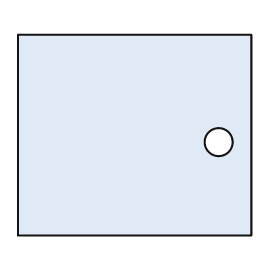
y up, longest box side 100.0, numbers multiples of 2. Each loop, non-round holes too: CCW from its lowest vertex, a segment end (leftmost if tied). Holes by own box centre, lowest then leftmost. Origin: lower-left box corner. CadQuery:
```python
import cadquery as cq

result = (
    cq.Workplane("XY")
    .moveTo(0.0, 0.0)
    .lineTo(100.0, 0.0)
    .lineTo(100.0, 86.0)
    .lineTo(0.0, 86.0)
    .close()
    .moveTo(86.0, 40.0)
    .circle(6.0)
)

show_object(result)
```